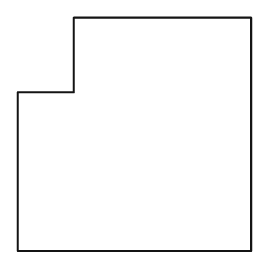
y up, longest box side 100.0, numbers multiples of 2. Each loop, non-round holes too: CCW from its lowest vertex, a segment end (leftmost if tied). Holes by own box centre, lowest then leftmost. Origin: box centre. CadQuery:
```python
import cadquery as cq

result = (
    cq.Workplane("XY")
    .moveTo(-50.0, -50.0)
    .lineTo(50.0, -50.0)
    .lineTo(50.0, 50.0)
    .lineTo(-26.0, 50.0)
    .lineTo(-26.0, 18.0)
    .lineTo(-50.0, 18.0)
    .close()
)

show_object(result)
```